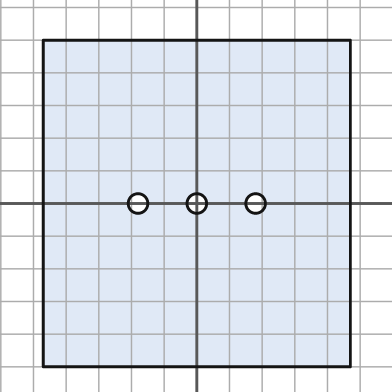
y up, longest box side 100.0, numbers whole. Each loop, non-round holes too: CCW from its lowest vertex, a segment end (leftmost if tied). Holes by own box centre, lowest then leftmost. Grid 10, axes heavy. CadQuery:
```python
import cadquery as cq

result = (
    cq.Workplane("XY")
    .moveTo(-47.0, -50.0)
    .lineTo(47.0, -50.0)
    .lineTo(47.0, 50.0)
    .lineTo(-47.0, 50.0)
    .close()
    .moveTo(-18.0, 0.0)
    .circle(3.0)
    .moveTo(0.0, 0.0)
    .circle(3.0)
    .moveTo(18.0, 0.0)
    .circle(3.0)
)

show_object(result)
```